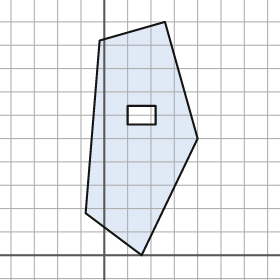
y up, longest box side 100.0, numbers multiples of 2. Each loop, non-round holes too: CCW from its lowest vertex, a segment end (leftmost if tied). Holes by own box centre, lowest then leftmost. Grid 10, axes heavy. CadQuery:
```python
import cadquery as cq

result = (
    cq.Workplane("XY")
    .moveTo(16.0, 0.0)
    .lineTo(40.0, 50.0)
    .lineTo(26.0, 100.0)
    .lineTo(-2.0, 92.0)
    .lineTo(-8.0, 18.0)
    .close()
    .moveTo(10.0, 56.0)
    .lineTo(22.0, 56.0)
    .lineTo(22.0, 64.0)
    .lineTo(10.0, 64.0)
    .close()
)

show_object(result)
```